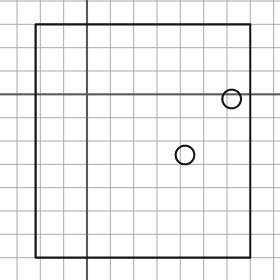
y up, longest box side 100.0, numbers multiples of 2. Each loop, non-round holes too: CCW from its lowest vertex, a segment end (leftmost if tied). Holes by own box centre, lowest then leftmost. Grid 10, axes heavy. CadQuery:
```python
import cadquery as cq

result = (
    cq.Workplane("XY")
    .moveTo(-22.0, -70.0)
    .lineTo(70.0, -70.0)
    .lineTo(70.0, 30.0)
    .lineTo(-22.0, 30.0)
    .close()
    .moveTo(42.0, -26.0)
    .circle(4.0)
    .moveTo(62.0, -2.0)
    .circle(4.0)
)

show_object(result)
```